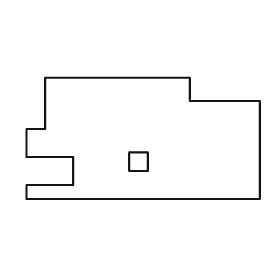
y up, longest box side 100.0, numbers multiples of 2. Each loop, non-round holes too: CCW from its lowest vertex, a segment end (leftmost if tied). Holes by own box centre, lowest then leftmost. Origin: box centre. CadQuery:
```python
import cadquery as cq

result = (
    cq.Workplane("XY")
    .moveTo(-50.0, -26.0)
    .lineTo(50.0, -26.0)
    .lineTo(50.0, 16.0)
    .lineTo(20.0, 16.0)
    .lineTo(20.0, 26.0)
    .lineTo(-42.0, 26.0)
    .lineTo(-42.0, 4.0)
    .lineTo(-50.0, 4.0)
    .lineTo(-50.0, -8.0)
    .lineTo(-30.0, -8.0)
    .lineTo(-30.0, -20.0)
    .lineTo(-50.0, -20.0)
    .close()
    .moveTo(-6.0, -14.0)
    .lineTo(2.0, -14.0)
    .lineTo(2.0, -6.0)
    .lineTo(-6.0, -6.0)
    .close()
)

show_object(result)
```